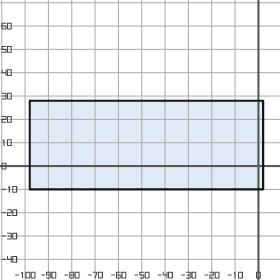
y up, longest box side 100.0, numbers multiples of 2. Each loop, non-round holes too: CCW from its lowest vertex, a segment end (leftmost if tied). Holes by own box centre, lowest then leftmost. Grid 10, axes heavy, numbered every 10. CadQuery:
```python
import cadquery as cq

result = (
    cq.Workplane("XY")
    .moveTo(-98.0, -10.0)
    .lineTo(2.0, -10.0)
    .lineTo(2.0, 28.0)
    .lineTo(-98.0, 28.0)
    .close()
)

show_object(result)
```